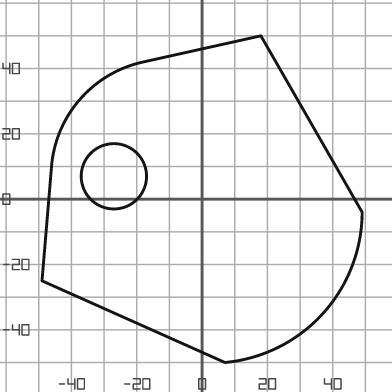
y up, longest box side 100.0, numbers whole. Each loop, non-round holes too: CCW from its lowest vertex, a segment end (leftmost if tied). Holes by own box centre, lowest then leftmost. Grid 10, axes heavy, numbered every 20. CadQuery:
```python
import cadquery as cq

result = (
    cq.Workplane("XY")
    .moveTo(7.0, -50.0)
    .threePointArc((37.0, -35.0), (49.0, -4.0))
    .lineTo(18.0, 50.0)
    .lineTo(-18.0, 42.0)
    .threePointArc((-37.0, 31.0), (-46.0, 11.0))
    .lineTo(-49.0, -25.0)
    .close()
    .moveTo(-27.0, 7.0)
    .circle(10.0)
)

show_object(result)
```